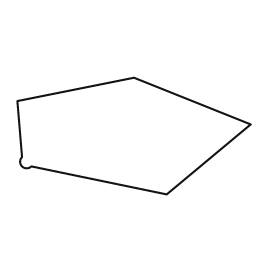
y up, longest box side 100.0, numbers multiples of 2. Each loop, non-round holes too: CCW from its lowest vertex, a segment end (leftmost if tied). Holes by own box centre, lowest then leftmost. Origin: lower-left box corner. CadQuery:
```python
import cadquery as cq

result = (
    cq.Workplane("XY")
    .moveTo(64.0, 0.0)
    .lineTo(100.0, 30.0)
    .lineTo(50.0, 50.0)
    .lineTo(0.0, 40.0)
    .lineTo(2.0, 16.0)
    .threePointArc((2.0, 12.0), (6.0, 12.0))
    .close()
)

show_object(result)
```